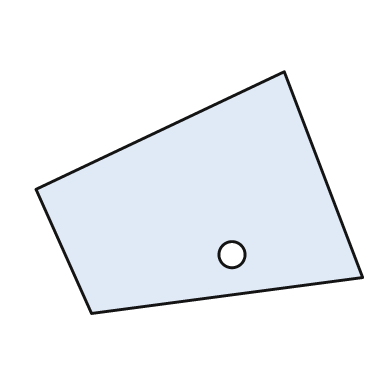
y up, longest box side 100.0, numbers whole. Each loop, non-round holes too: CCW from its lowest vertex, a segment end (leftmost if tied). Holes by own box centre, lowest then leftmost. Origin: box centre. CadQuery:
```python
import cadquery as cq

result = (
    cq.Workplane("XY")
    .moveTo(-33.0, -37.0)
    .lineTo(50.0, -26.0)
    .lineTo(26.0, 37.0)
    .lineTo(-50.0, 1.0)
    .close()
    .moveTo(10.0, -19.0)
    .circle(4.0)
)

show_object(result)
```